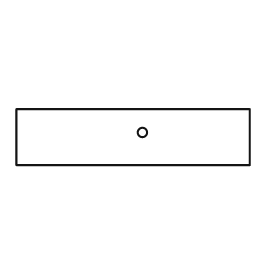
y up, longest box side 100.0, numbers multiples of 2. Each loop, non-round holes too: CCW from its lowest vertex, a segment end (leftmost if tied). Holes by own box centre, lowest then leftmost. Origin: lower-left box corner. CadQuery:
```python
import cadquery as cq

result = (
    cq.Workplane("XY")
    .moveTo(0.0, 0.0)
    .lineTo(100.0, 0.0)
    .lineTo(100.0, 24.0)
    .lineTo(0.0, 24.0)
    .close()
    .moveTo(54.0, 14.0)
    .circle(2.0)
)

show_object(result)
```